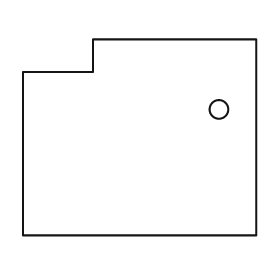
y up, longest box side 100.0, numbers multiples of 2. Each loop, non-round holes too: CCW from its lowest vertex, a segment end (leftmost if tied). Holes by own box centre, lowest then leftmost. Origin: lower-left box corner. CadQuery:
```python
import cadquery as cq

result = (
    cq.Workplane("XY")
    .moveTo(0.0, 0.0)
    .lineTo(100.0, 0.0)
    .lineTo(100.0, 84.0)
    .lineTo(30.0, 84.0)
    .lineTo(30.0, 70.0)
    .lineTo(0.0, 70.0)
    .close()
    .moveTo(84.0, 54.0)
    .circle(4.0)
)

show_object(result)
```